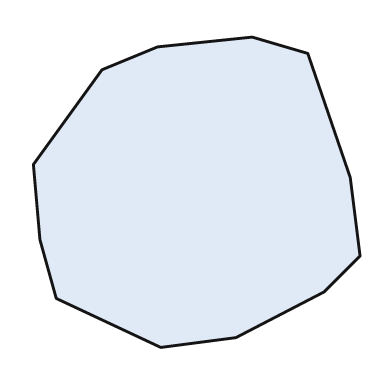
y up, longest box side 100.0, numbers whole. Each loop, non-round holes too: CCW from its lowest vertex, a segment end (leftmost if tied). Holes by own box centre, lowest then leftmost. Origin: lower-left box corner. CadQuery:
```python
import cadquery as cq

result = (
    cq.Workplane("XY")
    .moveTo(39.0, 0.0)
    .lineTo(62.0, 3.0)
    .lineTo(89.0, 17.0)
    .lineTo(100.0, 28.0)
    .lineTo(97.0, 52.0)
    .lineTo(84.0, 90.0)
    .lineTo(67.0, 95.0)
    .lineTo(38.0, 92.0)
    .lineTo(21.0, 85.0)
    .lineTo(0.0, 56.0)
    .lineTo(2.0, 33.0)
    .lineTo(7.0, 15.0)
    .close()
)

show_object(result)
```